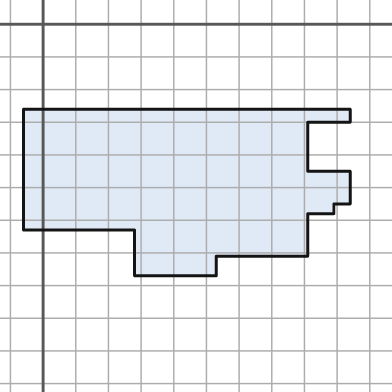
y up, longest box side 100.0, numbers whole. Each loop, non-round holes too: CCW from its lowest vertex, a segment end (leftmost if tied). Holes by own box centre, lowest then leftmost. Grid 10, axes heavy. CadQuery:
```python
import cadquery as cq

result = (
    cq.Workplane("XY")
    .moveTo(28.0, -77.0)
    .lineTo(53.0, -77.0)
    .lineTo(53.0, -71.0)
    .lineTo(81.0, -71.0)
    .lineTo(81.0, -58.0)
    .lineTo(89.0, -58.0)
    .lineTo(89.0, -55.0)
    .lineTo(94.0, -55.0)
    .lineTo(94.0, -45.0)
    .lineTo(81.0, -45.0)
    .lineTo(81.0, -30.0)
    .lineTo(94.0, -30.0)
    .lineTo(94.0, -26.0)
    .lineTo(-6.0, -26.0)
    .lineTo(-6.0, -63.0)
    .lineTo(28.0, -63.0)
    .close()
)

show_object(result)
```